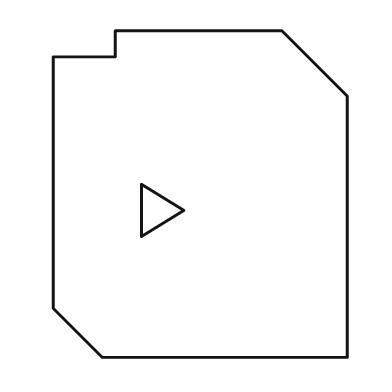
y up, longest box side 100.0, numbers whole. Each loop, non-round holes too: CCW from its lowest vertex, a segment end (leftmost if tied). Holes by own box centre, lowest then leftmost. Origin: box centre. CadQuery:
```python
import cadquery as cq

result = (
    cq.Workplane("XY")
    .moveTo(-30.0, -50.0)
    .lineTo(45.0, -50.0)
    .lineTo(45.0, 30.0)
    .lineTo(25.0, 50.0)
    .lineTo(-26.0, 50.0)
    .lineTo(-26.0, 42.0)
    .lineTo(-45.0, 42.0)
    .lineTo(-45.0, -35.0)
    .close()
    .moveTo(-18.0, -13.0)
    .lineTo(-5.0, -5.0)
    .lineTo(-18.0, 3.0)
    .close()
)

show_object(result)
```